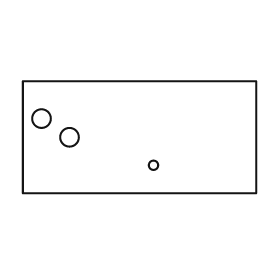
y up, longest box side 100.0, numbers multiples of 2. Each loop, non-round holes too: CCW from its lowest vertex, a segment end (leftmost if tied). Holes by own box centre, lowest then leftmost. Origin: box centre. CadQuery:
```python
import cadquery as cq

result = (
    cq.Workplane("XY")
    .moveTo(-50.0, -24.0)
    .lineTo(50.0, -24.0)
    .lineTo(50.0, 24.0)
    .lineTo(-50.0, 24.0)
    .close()
    .moveTo(6.0, -12.0)
    .circle(2.0)
    .moveTo(-30.0, 0.0)
    .circle(4.0)
    .moveTo(-42.0, 8.0)
    .circle(4.0)
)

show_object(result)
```